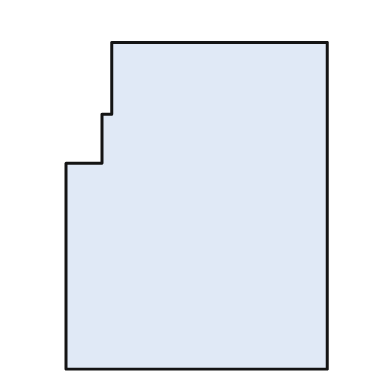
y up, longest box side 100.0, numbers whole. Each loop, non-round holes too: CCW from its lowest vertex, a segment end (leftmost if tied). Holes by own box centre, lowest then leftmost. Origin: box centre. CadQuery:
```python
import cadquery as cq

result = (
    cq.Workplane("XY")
    .moveTo(-40.0, -50.0)
    .lineTo(40.0, -50.0)
    .lineTo(40.0, 50.0)
    .lineTo(-26.0, 50.0)
    .lineTo(-26.0, 28.0)
    .lineTo(-29.0, 28.0)
    .lineTo(-29.0, 13.0)
    .lineTo(-40.0, 13.0)
    .close()
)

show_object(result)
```